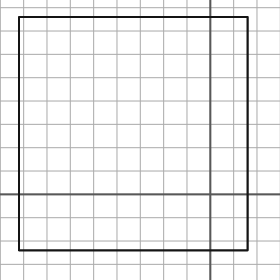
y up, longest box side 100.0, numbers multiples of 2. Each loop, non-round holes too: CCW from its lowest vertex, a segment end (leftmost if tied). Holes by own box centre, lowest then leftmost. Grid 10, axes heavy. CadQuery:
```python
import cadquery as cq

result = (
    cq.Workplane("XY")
    .moveTo(-82.0, -24.0)
    .lineTo(16.0, -24.0)
    .lineTo(16.0, 76.0)
    .lineTo(-82.0, 76.0)
    .close()
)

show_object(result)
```